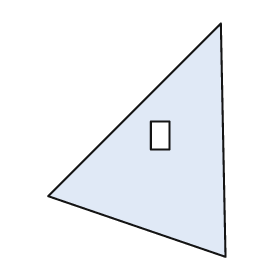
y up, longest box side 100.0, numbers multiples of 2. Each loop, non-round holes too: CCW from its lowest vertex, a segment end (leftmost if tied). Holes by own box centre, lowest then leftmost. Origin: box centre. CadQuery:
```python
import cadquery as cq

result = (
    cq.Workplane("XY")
    .moveTo(38.0, -50.0)
    .lineTo(36.0, 50.0)
    .lineTo(-38.0, -24.0)
    .close()
    .moveTo(6.0, -4.0)
    .lineTo(14.0, -4.0)
    .lineTo(14.0, 8.0)
    .lineTo(6.0, 8.0)
    .close()
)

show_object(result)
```